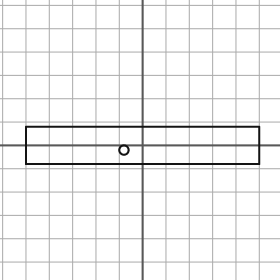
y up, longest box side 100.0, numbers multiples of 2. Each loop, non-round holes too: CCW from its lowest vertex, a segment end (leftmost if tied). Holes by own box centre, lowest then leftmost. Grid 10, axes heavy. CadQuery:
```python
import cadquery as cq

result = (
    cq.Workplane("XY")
    .moveTo(-50.0, -8.0)
    .lineTo(50.0, -8.0)
    .lineTo(50.0, 8.0)
    .lineTo(-50.0, 8.0)
    .close()
    .moveTo(-8.0, -2.0)
    .circle(2.0)
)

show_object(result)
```